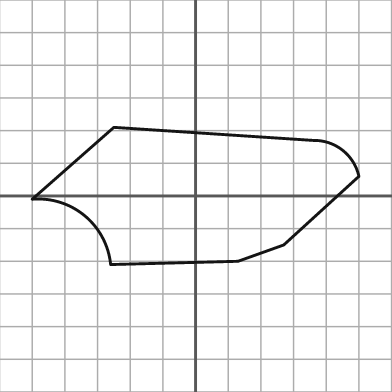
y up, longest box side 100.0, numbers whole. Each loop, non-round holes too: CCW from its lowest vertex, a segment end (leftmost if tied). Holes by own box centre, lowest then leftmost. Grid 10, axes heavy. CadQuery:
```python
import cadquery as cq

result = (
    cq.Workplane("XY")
    .moveTo(-26.0, -21.0)
    .lineTo(13.0, -20.0)
    .lineTo(27.0, -15.0)
    .lineTo(50.0, 6.0)
    .threePointArc((45.0, 14.0), (36.0, 17.0))
    .lineTo(-25.0, 21.0)
    .lineTo(-50.0, -1.0)
    .threePointArc((-34.0, -6.0), (-26.0, -21.0))
    .close()
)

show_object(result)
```